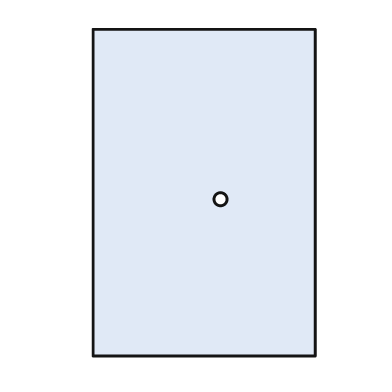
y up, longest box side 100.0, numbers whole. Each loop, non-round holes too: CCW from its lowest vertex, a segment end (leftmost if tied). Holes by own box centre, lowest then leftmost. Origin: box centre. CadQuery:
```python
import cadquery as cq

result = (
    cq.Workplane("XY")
    .moveTo(-34.0, -50.0)
    .lineTo(34.0, -50.0)
    .lineTo(34.0, 50.0)
    .lineTo(-34.0, 50.0)
    .close()
    .moveTo(5.0, -2.0)
    .circle(2.0)
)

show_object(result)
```